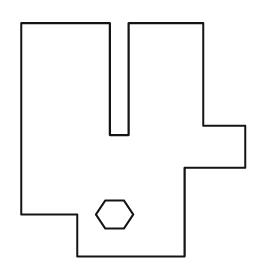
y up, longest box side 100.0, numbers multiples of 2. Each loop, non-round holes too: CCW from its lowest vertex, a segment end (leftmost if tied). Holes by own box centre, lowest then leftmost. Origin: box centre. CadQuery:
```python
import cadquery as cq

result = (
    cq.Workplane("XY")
    .moveTo(-24.0, -50.0)
    .lineTo(22.0, -50.0)
    .lineTo(22.0, -12.0)
    .lineTo(48.0, -12.0)
    .lineTo(48.0, 6.0)
    .lineTo(30.0, 6.0)
    .lineTo(30.0, 50.0)
    .lineTo(-2.0, 50.0)
    .lineTo(-2.0, 2.0)
    .lineTo(-10.0, 2.0)
    .lineTo(-10.0, 50.0)
    .lineTo(-48.0, 50.0)
    .lineTo(-48.0, -32.0)
    .lineTo(-24.0, -32.0)
    .close()
    .moveTo(-12.0, -38.0)
    .lineTo(-4.0, -38.0)
    .lineTo(0.0, -32.0)
    .lineTo(-4.0, -26.0)
    .lineTo(-12.0, -26.0)
    .lineTo(-16.0, -32.0)
    .close()
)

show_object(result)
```